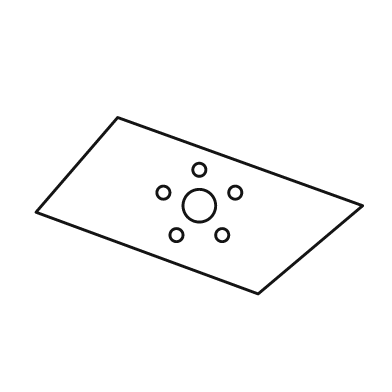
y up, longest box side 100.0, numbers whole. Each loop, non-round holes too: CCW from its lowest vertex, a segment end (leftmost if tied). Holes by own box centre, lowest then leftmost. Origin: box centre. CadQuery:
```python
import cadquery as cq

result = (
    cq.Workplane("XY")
    .moveTo(18.0, -27.0)
    .lineTo(50.0, 0.0)
    .lineTo(-25.0, 27.0)
    .lineTo(-50.0, -2.0)
    .close()
    .moveTo(-7.0, -9.0)
    .circle(2.0)
    .moveTo(7.0, -9.0)
    .circle(2.0)
    .moveTo(0.0, 0.0)
    .circle(5.0)
    .moveTo(-11.0, 4.0)
    .circle(2.0)
    .moveTo(11.0, 4.0)
    .circle(2.0)
    .moveTo(0.0, 11.0)
    .circle(2.0)
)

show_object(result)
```